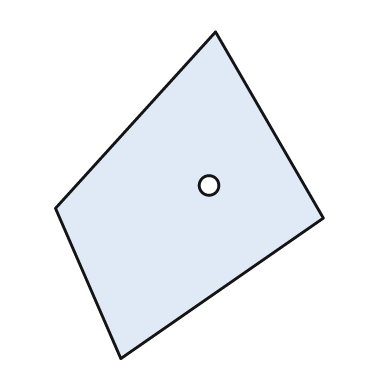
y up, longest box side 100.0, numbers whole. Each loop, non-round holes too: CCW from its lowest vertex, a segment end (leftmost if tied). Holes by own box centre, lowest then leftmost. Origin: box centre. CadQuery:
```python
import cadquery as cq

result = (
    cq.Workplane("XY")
    .moveTo(-21.0, -50.0)
    .lineTo(41.0, -7.0)
    .lineTo(8.0, 50.0)
    .lineTo(-41.0, -4.0)
    .close()
    .moveTo(6.0, 3.0)
    .circle(3.0)
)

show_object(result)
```